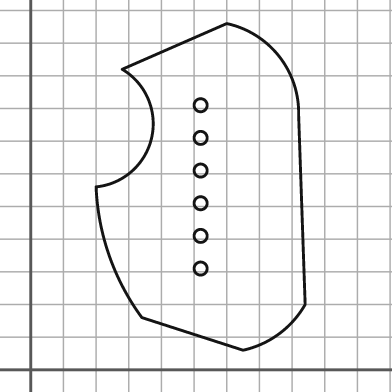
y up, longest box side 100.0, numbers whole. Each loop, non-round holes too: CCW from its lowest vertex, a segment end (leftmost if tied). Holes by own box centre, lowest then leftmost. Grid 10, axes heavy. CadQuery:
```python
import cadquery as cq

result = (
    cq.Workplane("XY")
    .moveTo(65.0, 6.0)
    .threePointArc((76.0, 11.0), (84.0, 20.0))
    .lineTo(82.0, 78.0)
    .threePointArc((76.0, 96.0), (60.0, 106.0))
    .lineTo(28.0, 92.0)
    .threePointArc((37.0, 71.0), (20.0, 56.0))
    .threePointArc((24.0, 35.0), (34.0, 16.0))
    .close()
    .moveTo(52.0, 31.0)
    .circle(2.0)
    .moveTo(52.0, 41.0)
    .circle(2.0)
    .moveTo(52.0, 51.0)
    .circle(2.0)
    .moveTo(52.0, 61.0)
    .circle(2.0)
    .moveTo(52.0, 71.0)
    .circle(2.0)
    .moveTo(52.0, 81.0)
    .circle(2.0)
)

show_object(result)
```